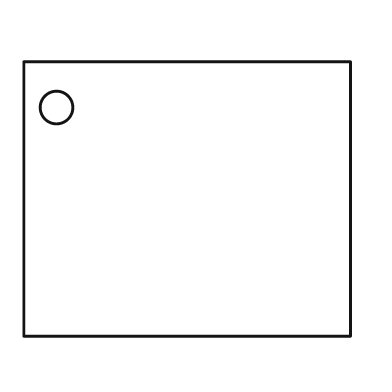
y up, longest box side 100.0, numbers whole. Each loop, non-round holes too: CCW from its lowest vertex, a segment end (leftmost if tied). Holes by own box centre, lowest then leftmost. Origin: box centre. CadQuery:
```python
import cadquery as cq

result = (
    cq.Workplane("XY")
    .moveTo(-50.0, -42.0)
    .lineTo(50.0, -42.0)
    .lineTo(50.0, 42.0)
    .lineTo(-50.0, 42.0)
    .close()
    .moveTo(-40.0, 28.0)
    .circle(5.0)
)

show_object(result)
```